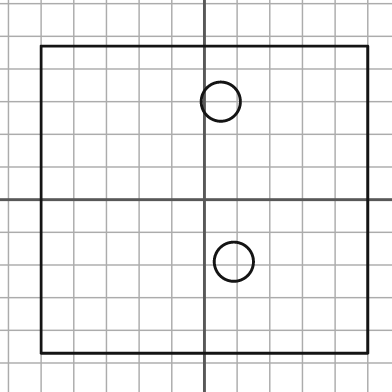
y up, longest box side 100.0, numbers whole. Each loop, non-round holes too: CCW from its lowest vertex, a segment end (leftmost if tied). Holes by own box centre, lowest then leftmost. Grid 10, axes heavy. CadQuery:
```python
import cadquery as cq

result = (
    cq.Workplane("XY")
    .moveTo(-50.0, -47.0)
    .lineTo(50.0, -47.0)
    .lineTo(50.0, 47.0)
    .lineTo(-50.0, 47.0)
    .close()
    .moveTo(9.0, -19.0)
    .circle(6.0)
    .moveTo(5.0, 30.0)
    .circle(6.0)
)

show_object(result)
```